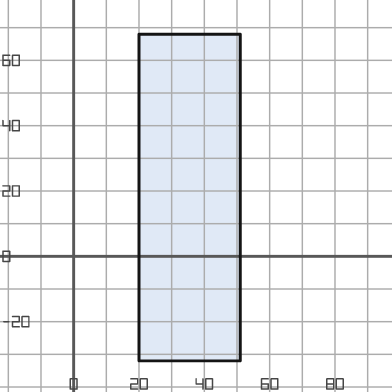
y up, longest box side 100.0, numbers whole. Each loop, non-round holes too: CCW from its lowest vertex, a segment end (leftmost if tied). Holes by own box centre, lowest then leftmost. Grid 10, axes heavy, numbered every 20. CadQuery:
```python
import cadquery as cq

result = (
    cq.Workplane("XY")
    .moveTo(20.0, -32.0)
    .lineTo(51.0, -32.0)
    .lineTo(51.0, 68.0)
    .lineTo(20.0, 68.0)
    .close()
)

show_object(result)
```